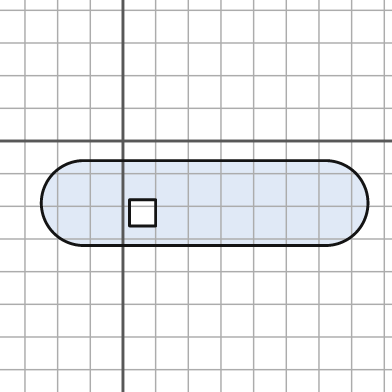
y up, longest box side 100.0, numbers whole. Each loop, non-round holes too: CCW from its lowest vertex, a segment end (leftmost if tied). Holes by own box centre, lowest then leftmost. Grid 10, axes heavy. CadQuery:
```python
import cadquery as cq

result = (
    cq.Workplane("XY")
    .moveTo(-12.0, -32.0)
    .lineTo(62.0, -32.0)
    .threePointArc((75.0, -19.0), (62.0, -6.0))
    .lineTo(-12.0, -6.0)
    .threePointArc((-25.0, -19.0), (-12.0, -32.0))
    .close()
    .moveTo(2.0, -26.0)
    .lineTo(10.0, -26.0)
    .lineTo(10.0, -18.0)
    .lineTo(2.0, -18.0)
    .close()
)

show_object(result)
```